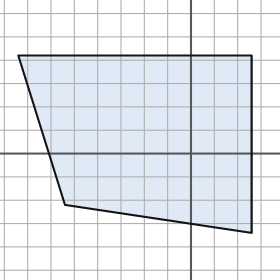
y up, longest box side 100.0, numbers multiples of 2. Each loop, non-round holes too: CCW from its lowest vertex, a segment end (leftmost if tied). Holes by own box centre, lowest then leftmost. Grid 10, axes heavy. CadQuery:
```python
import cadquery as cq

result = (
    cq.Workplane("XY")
    .moveTo(26.0, -34.0)
    .lineTo(26.0, 42.0)
    .lineTo(-74.0, 42.0)
    .lineTo(-54.0, -22.0)
    .close()
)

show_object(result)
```